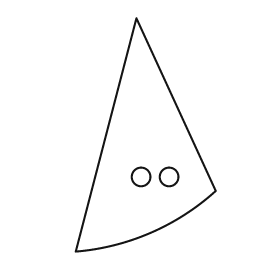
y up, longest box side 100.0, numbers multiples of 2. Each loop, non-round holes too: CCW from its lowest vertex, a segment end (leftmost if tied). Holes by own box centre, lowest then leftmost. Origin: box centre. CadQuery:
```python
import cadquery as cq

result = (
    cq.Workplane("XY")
    .moveTo(-30.0, -50.0)
    .threePointArc((2.0, -42.0), (30.0, -24.0))
    .lineTo(-4.0, 50.0)
    .close()
    .moveTo(-2.0, -18.0)
    .circle(4.0)
    .moveTo(10.0, -18.0)
    .circle(4.0)
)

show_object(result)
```